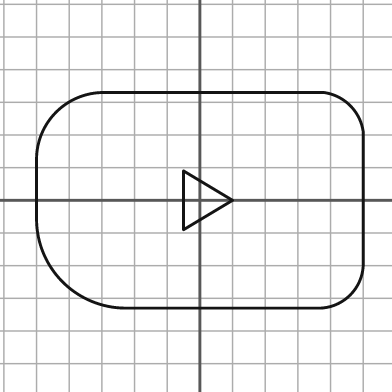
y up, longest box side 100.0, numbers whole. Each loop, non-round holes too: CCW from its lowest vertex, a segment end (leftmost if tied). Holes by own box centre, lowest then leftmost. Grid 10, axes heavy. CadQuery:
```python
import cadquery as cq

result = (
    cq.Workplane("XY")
    .moveTo(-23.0, -33.0)
    .lineTo(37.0, -33.0)
    .threePointArc((46.0, -29.0), (50.0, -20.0))
    .lineTo(50.0, 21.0)
    .threePointArc((46.0, 29.0), (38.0, 33.0))
    .lineTo(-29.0, 33.0)
    .threePointArc((-44.0, 27.0), (-50.0, 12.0))
    .lineTo(-50.0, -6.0)
    .threePointArc((-42.0, -25.0), (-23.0, -33.0))
    .close()
    .moveTo(-5.0, -9.0)
    .lineTo(10.0, 0.0)
    .lineTo(-5.0, 9.0)
    .close()
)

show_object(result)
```